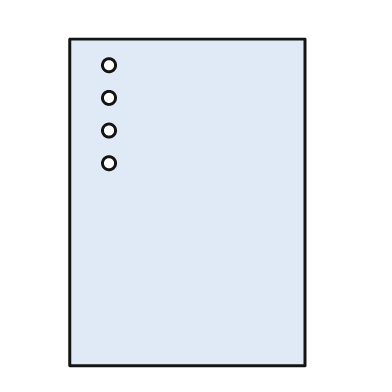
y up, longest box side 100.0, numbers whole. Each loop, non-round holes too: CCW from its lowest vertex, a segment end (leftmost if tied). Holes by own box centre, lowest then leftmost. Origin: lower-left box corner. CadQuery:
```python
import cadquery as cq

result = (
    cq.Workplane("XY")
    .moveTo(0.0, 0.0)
    .lineTo(72.0, 0.0)
    .lineTo(72.0, 100.0)
    .lineTo(0.0, 100.0)
    .close()
    .moveTo(12.0, 62.0)
    .circle(2.0)
    .moveTo(12.0, 72.0)
    .circle(2.0)
    .moveTo(12.0, 82.0)
    .circle(2.0)
    .moveTo(12.0, 92.0)
    .circle(2.0)
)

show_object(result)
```